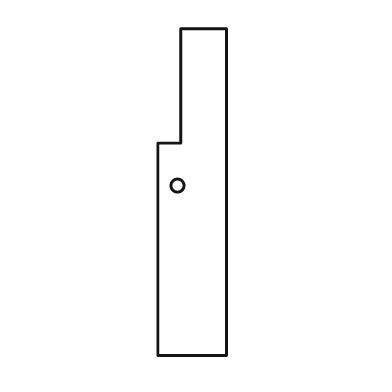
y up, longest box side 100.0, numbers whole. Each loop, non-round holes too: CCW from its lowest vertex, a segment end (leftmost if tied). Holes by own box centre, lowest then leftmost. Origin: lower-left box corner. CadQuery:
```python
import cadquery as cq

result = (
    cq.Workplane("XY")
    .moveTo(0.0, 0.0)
    .lineTo(21.0, 0.0)
    .lineTo(21.0, 100.0)
    .lineTo(7.0, 100.0)
    .lineTo(7.0, 65.0)
    .lineTo(0.0, 65.0)
    .close()
    .moveTo(6.0, 52.0)
    .circle(2.0)
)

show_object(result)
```